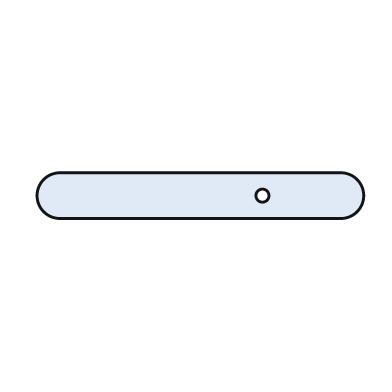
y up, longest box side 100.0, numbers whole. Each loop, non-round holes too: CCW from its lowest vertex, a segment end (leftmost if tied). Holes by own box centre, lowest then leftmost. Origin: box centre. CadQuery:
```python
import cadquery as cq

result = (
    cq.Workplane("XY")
    .moveTo(-43.0, -7.0)
    .lineTo(43.0, -7.0)
    .threePointArc((50.0, 0.0), (43.0, 7.0))
    .lineTo(-43.0, 7.0)
    .threePointArc((-50.0, 0.0), (-43.0, -7.0))
    .close()
    .moveTo(19.0, 0.0)
    .circle(2.0)
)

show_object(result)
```